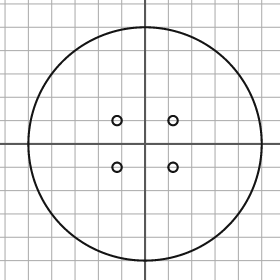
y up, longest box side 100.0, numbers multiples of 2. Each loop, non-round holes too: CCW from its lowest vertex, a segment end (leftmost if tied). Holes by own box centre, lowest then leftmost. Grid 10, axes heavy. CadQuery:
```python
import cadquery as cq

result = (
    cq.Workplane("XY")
    .moveTo(0.0, 0.0)
    .circle(50.0)
    .moveTo(-12.0, -10.0)
    .circle(2.0)
    .moveTo(12.0, -10.0)
    .circle(2.0)
    .moveTo(-12.0, 10.0)
    .circle(2.0)
    .moveTo(12.0, 10.0)
    .circle(2.0)
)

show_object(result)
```